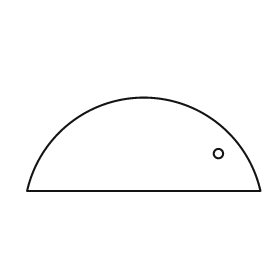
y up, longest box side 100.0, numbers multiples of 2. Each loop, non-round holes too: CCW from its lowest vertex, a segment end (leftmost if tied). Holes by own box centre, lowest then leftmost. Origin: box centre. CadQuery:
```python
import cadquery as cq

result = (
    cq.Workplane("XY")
    .moveTo(-50.0, -20.0)
    .lineTo(50.0, -20.0)
    .threePointArc((0.0, 20.0), (-50.0, -20.0))
    .close()
    .moveTo(32.0, -4.0)
    .circle(2.0)
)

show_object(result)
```